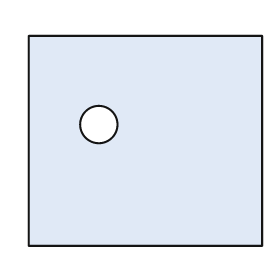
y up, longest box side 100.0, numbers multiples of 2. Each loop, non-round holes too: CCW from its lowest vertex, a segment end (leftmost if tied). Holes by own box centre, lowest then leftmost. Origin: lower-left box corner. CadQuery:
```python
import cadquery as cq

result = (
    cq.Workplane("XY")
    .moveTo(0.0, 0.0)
    .lineTo(100.0, 0.0)
    .lineTo(100.0, 90.0)
    .lineTo(0.0, 90.0)
    .close()
    .moveTo(30.0, 52.0)
    .circle(8.0)
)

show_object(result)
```